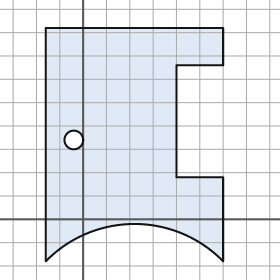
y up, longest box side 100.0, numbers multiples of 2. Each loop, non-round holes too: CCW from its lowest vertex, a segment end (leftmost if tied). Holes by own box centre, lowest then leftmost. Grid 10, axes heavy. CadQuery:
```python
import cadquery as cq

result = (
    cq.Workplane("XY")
    .moveTo(-16.0, -18.0)
    .threePointArc((22.0, -2.0), (60.0, -18.0))
    .lineTo(60.0, 18.0)
    .lineTo(40.0, 18.0)
    .lineTo(40.0, 66.0)
    .lineTo(60.0, 66.0)
    .lineTo(60.0, 82.0)
    .lineTo(-16.0, 82.0)
    .close()
    .moveTo(-4.0, 34.0)
    .circle(4.0)
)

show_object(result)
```